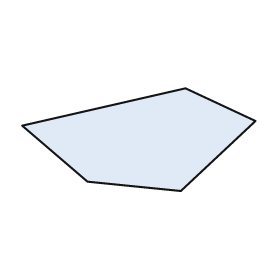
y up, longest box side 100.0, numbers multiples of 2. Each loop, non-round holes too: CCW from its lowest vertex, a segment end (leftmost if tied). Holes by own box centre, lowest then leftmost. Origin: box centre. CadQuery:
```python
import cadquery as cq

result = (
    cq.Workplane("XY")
    .moveTo(18.0, -22.0)
    .lineTo(50.0, 8.0)
    .lineTo(20.0, 22.0)
    .lineTo(-50.0, 6.0)
    .lineTo(-22.0, -18.0)
    .close()
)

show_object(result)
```